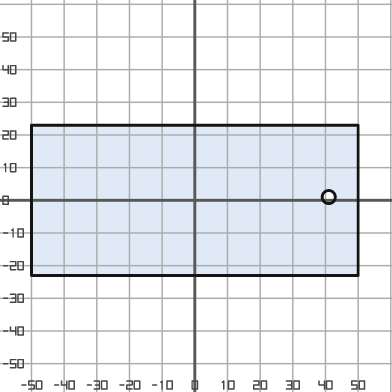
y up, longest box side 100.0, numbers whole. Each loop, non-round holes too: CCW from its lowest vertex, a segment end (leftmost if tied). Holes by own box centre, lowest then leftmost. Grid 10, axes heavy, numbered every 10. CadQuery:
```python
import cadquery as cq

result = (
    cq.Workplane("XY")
    .moveTo(-50.0, -23.0)
    .lineTo(50.0, -23.0)
    .lineTo(50.0, 23.0)
    .lineTo(-50.0, 23.0)
    .close()
    .moveTo(41.0, 1.0)
    .circle(2.0)
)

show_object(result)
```